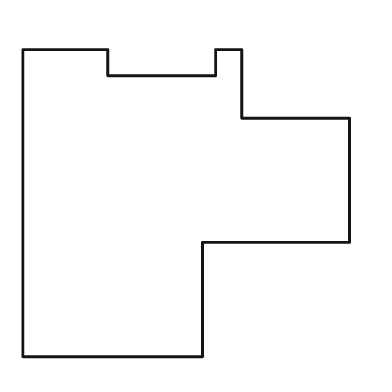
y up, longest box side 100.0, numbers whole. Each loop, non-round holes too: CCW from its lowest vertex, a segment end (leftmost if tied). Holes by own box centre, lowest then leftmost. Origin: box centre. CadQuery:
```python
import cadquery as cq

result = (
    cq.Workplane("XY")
    .moveTo(-50.0, -47.0)
    .lineTo(5.0, -47.0)
    .lineTo(5.0, -12.0)
    .lineTo(50.0, -12.0)
    .lineTo(50.0, 26.0)
    .lineTo(17.0, 26.0)
    .lineTo(17.0, 47.0)
    .lineTo(9.0, 47.0)
    .lineTo(9.0, 39.0)
    .lineTo(-24.0, 39.0)
    .lineTo(-24.0, 47.0)
    .lineTo(-50.0, 47.0)
    .close()
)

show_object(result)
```